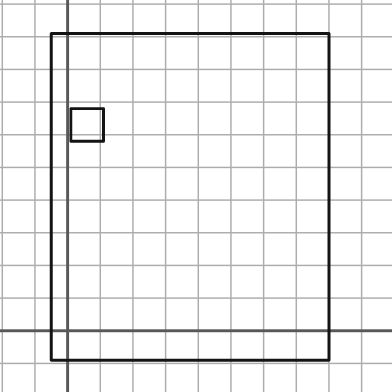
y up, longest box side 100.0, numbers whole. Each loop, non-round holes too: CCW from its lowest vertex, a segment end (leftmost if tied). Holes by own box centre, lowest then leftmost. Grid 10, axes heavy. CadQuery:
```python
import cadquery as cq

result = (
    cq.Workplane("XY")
    .moveTo(-5.0, -9.0)
    .lineTo(80.0, -9.0)
    .lineTo(80.0, 91.0)
    .lineTo(-5.0, 91.0)
    .close()
    .moveTo(1.0, 58.0)
    .lineTo(11.0, 58.0)
    .lineTo(11.0, 68.0)
    .lineTo(1.0, 68.0)
    .close()
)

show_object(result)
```